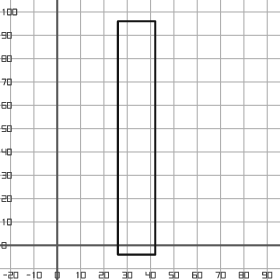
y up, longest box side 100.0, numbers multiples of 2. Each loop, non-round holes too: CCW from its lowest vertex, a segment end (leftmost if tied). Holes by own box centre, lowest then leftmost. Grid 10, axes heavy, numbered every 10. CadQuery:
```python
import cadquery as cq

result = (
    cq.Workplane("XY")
    .moveTo(26.0, -4.0)
    .lineTo(42.0, -4.0)
    .lineTo(42.0, 96.0)
    .lineTo(26.0, 96.0)
    .close()
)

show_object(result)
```